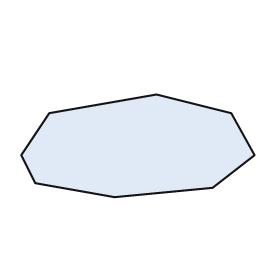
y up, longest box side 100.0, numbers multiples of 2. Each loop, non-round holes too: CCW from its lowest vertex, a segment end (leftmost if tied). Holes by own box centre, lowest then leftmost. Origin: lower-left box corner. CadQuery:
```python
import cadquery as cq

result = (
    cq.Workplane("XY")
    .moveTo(40.0, 0.0)
    .lineTo(82.0, 4.0)
    .lineTo(100.0, 18.0)
    .lineTo(90.0, 36.0)
    .lineTo(58.0, 44.0)
    .lineTo(12.0, 36.0)
    .lineTo(0.0, 18.0)
    .lineTo(6.0, 6.0)
    .close()
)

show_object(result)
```